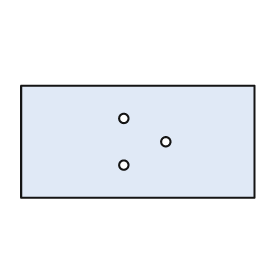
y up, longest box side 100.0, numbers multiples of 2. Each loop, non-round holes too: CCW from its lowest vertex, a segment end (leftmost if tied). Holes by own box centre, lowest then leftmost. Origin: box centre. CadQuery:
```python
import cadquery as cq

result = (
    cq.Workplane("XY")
    .moveTo(-50.0, -24.0)
    .lineTo(50.0, -24.0)
    .lineTo(50.0, 24.0)
    .lineTo(-50.0, 24.0)
    .close()
    .moveTo(-6.0, -10.0)
    .circle(2.0)
    .moveTo(12.0, 0.0)
    .circle(2.0)
    .moveTo(-6.0, 10.0)
    .circle(2.0)
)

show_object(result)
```